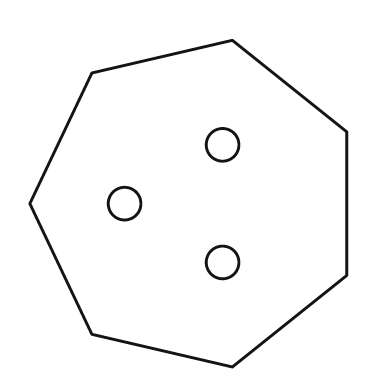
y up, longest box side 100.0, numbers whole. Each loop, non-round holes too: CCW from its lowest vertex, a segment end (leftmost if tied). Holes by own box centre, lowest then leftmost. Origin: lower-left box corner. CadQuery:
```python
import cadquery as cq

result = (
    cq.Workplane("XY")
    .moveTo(62.0, 0.0)
    .lineTo(97.0, 28.0)
    .lineTo(97.0, 72.0)
    .lineTo(62.0, 100.0)
    .lineTo(19.0, 90.0)
    .lineTo(0.0, 50.0)
    .lineTo(19.0, 10.0)
    .close()
    .moveTo(59.0, 32.0)
    .circle(5.0)
    .moveTo(29.0, 50.0)
    .circle(5.0)
    .moveTo(59.0, 68.0)
    .circle(5.0)
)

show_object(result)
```